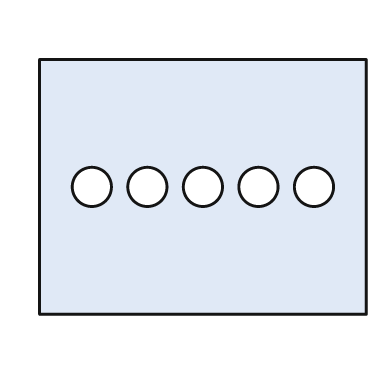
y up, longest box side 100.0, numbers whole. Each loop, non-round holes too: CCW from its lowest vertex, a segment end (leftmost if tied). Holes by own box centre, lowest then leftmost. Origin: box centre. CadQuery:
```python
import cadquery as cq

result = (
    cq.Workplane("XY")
    .moveTo(-50.0, -39.0)
    .lineTo(50.0, -39.0)
    .lineTo(50.0, 39.0)
    .lineTo(-50.0, 39.0)
    .close()
    .moveTo(-34.0, 0.0)
    .circle(6.0)
    .moveTo(-17.0, 0.0)
    .circle(6.0)
    .moveTo(0.0, 0.0)
    .circle(6.0)
    .moveTo(17.0, 0.0)
    .circle(6.0)
    .moveTo(34.0, 0.0)
    .circle(6.0)
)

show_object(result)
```